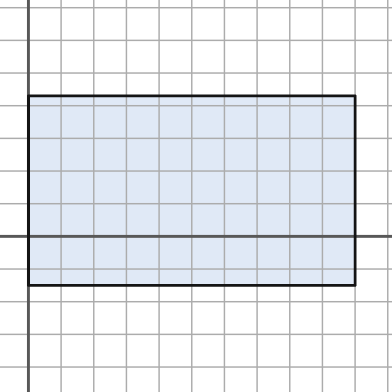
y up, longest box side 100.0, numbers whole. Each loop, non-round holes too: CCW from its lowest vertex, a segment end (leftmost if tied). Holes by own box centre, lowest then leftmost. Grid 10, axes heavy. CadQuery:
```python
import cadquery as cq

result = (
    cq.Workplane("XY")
    .moveTo(0.0, -15.0)
    .lineTo(100.0, -15.0)
    .lineTo(100.0, 43.0)
    .lineTo(0.0, 43.0)
    .close()
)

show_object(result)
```